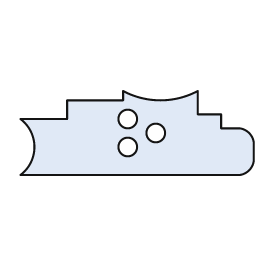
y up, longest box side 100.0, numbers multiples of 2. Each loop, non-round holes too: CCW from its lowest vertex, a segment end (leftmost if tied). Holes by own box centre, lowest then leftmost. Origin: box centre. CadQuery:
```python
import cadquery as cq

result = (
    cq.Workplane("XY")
    .moveTo(-50.0, -18.0)
    .lineTo(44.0, -18.0)
    .threePointArc((48.0, -16.0), (50.0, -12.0))
    .lineTo(50.0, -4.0)
    .threePointArc((48.0, 0.0), (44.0, 2.0))
    .lineTo(36.0, 2.0)
    .lineTo(36.0, 8.0)
    .lineTo(26.0, 8.0)
    .lineTo(26.0, 18.0)
    .threePointArc((10.0, 14.0), (-6.0, 18.0))
    .lineTo(-6.0, 14.0)
    .lineTo(-30.0, 14.0)
    .lineTo(-30.0, 6.0)
    .lineTo(-50.0, 6.0)
    .threePointArc((-44.0, -6.0), (-50.0, -18.0))
    .close()
    .moveTo(-4.0, -6.0)
    .circle(4.0)
    .moveTo(8.0, 0.0)
    .circle(4.0)
    .moveTo(-4.0, 6.0)
    .circle(4.0)
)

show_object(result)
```